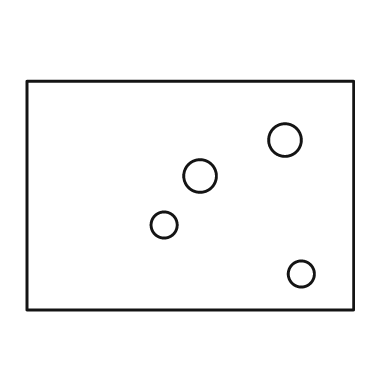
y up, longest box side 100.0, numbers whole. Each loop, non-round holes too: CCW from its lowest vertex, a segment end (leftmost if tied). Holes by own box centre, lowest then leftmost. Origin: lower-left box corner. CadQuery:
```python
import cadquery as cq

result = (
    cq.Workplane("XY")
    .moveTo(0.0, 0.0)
    .lineTo(100.0, 0.0)
    .lineTo(100.0, 70.0)
    .lineTo(0.0, 70.0)
    .close()
    .moveTo(84.0, 11.0)
    .circle(4.0)
    .moveTo(42.0, 26.0)
    .circle(4.0)
    .moveTo(53.0, 41.0)
    .circle(5.0)
    .moveTo(79.0, 52.0)
    .circle(5.0)
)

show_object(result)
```